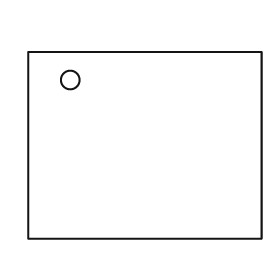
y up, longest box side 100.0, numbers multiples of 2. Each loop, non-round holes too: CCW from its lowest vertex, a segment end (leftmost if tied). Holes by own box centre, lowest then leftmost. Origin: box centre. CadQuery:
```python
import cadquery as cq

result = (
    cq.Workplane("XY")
    .moveTo(-50.0, -40.0)
    .lineTo(50.0, -40.0)
    .lineTo(50.0, 40.0)
    .lineTo(-50.0, 40.0)
    .close()
    .moveTo(-32.0, 28.0)
    .circle(4.0)
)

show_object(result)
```